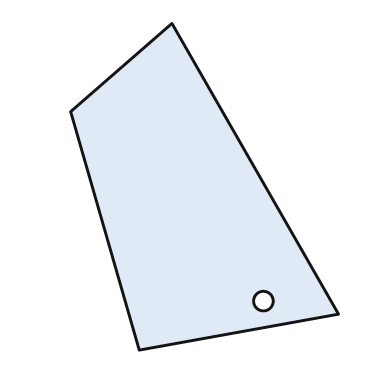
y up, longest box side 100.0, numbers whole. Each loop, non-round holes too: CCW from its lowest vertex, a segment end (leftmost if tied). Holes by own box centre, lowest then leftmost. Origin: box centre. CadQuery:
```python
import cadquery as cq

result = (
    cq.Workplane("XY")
    .moveTo(-20.0, -50.0)
    .lineTo(41.0, -39.0)
    .lineTo(-10.0, 50.0)
    .lineTo(-41.0, 23.0)
    .close()
    .moveTo(18.0, -35.0)
    .circle(3.0)
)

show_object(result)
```